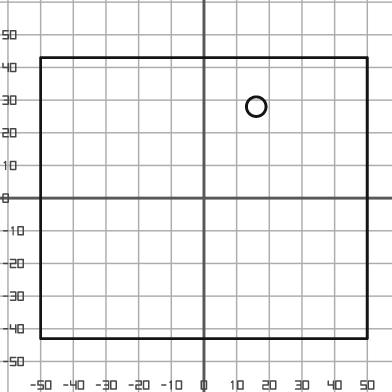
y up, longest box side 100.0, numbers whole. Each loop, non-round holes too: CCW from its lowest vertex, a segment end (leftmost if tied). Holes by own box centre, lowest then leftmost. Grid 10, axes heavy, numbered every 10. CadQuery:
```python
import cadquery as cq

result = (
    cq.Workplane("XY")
    .moveTo(-50.0, -43.0)
    .lineTo(50.0, -43.0)
    .lineTo(50.0, 43.0)
    .lineTo(-50.0, 43.0)
    .close()
    .moveTo(16.0, 28.0)
    .circle(3.0)
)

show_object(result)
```